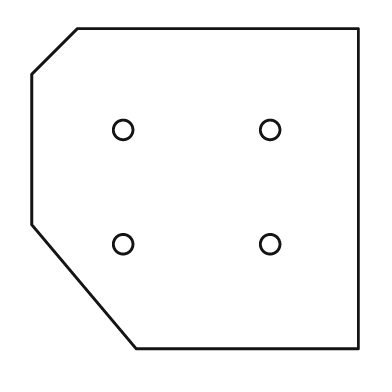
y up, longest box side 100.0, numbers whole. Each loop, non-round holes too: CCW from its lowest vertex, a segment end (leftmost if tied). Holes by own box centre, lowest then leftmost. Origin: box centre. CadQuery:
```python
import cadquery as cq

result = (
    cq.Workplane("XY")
    .moveTo(-18.0, -49.0)
    .lineTo(50.0, -49.0)
    .lineTo(50.0, 49.0)
    .lineTo(-36.0, 49.0)
    .lineTo(-50.0, 35.0)
    .lineTo(-50.0, -11.0)
    .close()
    .moveTo(-22.0, -17.0)
    .circle(3.0)
    .moveTo(23.0, -17.0)
    .circle(3.0)
    .moveTo(-22.0, 18.0)
    .circle(3.0)
    .moveTo(23.0, 18.0)
    .circle(3.0)
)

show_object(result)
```